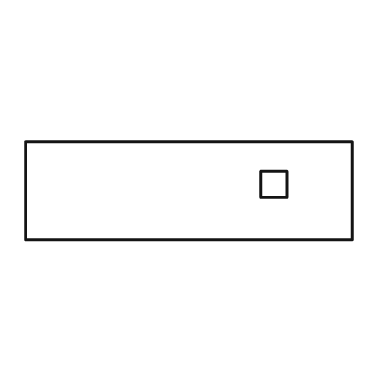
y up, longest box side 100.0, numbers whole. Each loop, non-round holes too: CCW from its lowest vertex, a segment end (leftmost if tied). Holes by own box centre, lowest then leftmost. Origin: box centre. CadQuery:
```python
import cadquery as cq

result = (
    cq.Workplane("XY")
    .moveTo(-50.0, -15.0)
    .lineTo(50.0, -15.0)
    .lineTo(50.0, 15.0)
    .lineTo(-50.0, 15.0)
    .close()
    .moveTo(22.0, -2.0)
    .lineTo(30.0, -2.0)
    .lineTo(30.0, 6.0)
    .lineTo(22.0, 6.0)
    .close()
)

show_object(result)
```